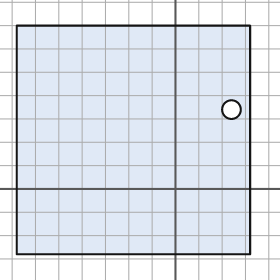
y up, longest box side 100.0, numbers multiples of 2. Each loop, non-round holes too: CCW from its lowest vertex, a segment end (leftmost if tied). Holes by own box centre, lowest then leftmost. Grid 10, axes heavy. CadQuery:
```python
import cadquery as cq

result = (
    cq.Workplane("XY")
    .moveTo(-68.0, -28.0)
    .lineTo(32.0, -28.0)
    .lineTo(32.0, 70.0)
    .lineTo(-68.0, 70.0)
    .close()
    .moveTo(24.0, 34.0)
    .circle(4.0)
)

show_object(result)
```